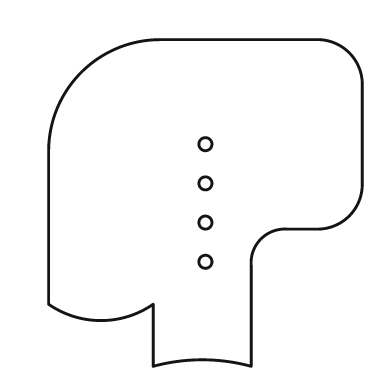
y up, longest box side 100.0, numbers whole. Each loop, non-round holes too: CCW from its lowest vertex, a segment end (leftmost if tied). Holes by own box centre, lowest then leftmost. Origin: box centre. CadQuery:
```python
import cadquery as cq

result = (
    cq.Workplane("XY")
    .moveTo(-16.0, -50.0)
    .threePointArc((-1.0, -48.0), (14.0, -50.0))
    .lineTo(14.0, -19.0)
    .threePointArc((17.0, -11.0), (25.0, -8.0))
    .lineTo(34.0, -8.0)
    .threePointArc((44.0, -4.0), (48.0, 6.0))
    .lineTo(48.0, 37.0)
    .threePointArc((44.0, 46.0), (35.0, 50.0))
    .lineTo(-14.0, 50.0)
    .threePointArc((-38.0, 40.0), (-48.0, 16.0))
    .lineTo(-48.0, -31.0)
    .threePointArc((-32.0, -36.0), (-16.0, -31.0))
    .close()
    .moveTo(0.0, -18.0)
    .circle(2.0)
    .moveTo(0.0, -6.0)
    .circle(2.0)
    .moveTo(0.0, 6.0)
    .circle(2.0)
    .moveTo(0.0, 18.0)
    .circle(2.0)
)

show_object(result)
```